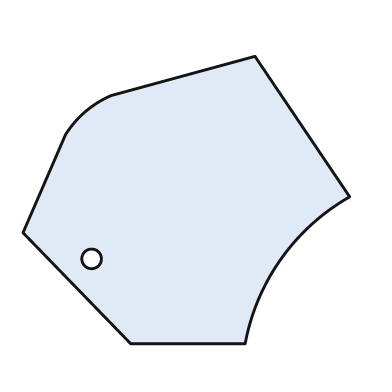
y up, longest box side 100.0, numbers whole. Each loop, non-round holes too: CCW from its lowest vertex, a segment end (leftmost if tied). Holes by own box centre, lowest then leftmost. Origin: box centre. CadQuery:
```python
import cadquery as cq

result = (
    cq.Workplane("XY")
    .moveTo(-17.0, -44.0)
    .lineTo(18.0, -44.0)
    .threePointArc((29.0, -18.0), (50.0, 1.0))
    .lineTo(21.0, 44.0)
    .lineTo(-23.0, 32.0)
    .threePointArc((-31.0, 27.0), (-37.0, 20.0))
    .lineTo(-50.0, -10.0)
    .close()
    .moveTo(-29.0, -18.0)
    .circle(3.0)
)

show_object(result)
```